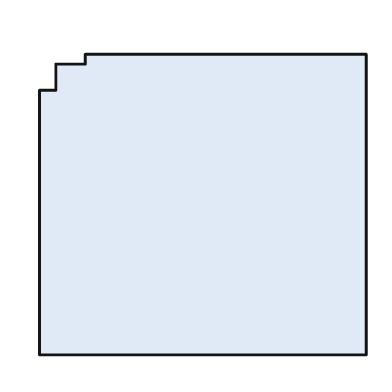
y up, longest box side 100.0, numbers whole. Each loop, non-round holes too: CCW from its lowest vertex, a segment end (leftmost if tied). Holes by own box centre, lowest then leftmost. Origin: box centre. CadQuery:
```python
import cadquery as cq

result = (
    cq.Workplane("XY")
    .moveTo(-50.0, -46.0)
    .lineTo(50.0, -46.0)
    .lineTo(50.0, 46.0)
    .lineTo(-36.0, 46.0)
    .lineTo(-36.0, 43.0)
    .lineTo(-45.0, 43.0)
    .lineTo(-45.0, 35.0)
    .lineTo(-50.0, 35.0)
    .close()
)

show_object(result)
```